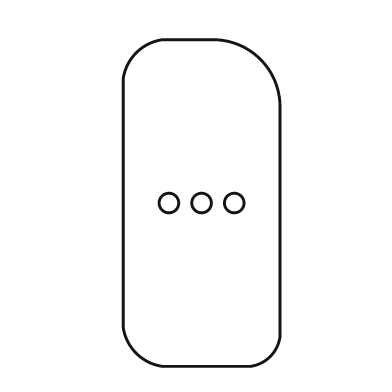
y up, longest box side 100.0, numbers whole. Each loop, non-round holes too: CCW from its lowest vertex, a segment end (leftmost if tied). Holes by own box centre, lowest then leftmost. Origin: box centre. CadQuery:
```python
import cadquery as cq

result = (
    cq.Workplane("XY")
    .moveTo(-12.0, -50.0)
    .lineTo(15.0, -50.0)
    .threePointArc((21.0, -47.0), (24.0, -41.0))
    .lineTo(24.0, 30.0)
    .threePointArc((18.0, 44.0), (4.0, 50.0))
    .lineTo(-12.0, 50.0)
    .threePointArc((-20.0, 46.0), (-24.0, 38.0))
    .lineTo(-24.0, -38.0)
    .threePointArc((-20.0, -46.0), (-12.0, -50.0))
    .close()
    .moveTo(-10.0, 0.0)
    .circle(3.0)
    .moveTo(0.0, 0.0)
    .circle(3.0)
    .moveTo(10.0, 0.0)
    .circle(3.0)
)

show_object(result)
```